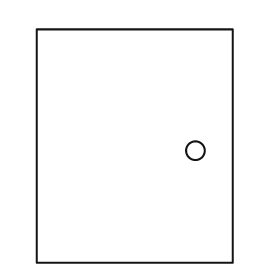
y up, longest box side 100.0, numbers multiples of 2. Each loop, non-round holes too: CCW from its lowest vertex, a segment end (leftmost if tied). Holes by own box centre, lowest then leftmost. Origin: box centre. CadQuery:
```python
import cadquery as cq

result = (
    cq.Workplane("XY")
    .moveTo(-42.0, -50.0)
    .lineTo(42.0, -50.0)
    .lineTo(42.0, 50.0)
    .lineTo(-42.0, 50.0)
    .close()
    .moveTo(26.0, -2.0)
    .circle(4.0)
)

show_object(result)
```